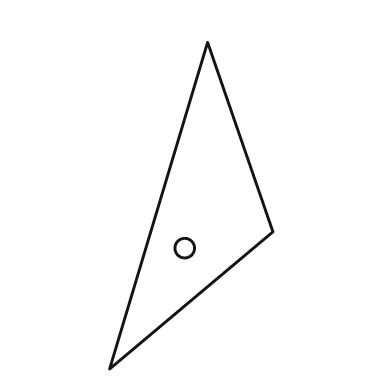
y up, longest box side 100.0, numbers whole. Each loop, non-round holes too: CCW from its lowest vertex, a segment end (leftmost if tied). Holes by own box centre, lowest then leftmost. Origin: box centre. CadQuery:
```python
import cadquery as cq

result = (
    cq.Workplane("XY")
    .moveTo(-25.0, -50.0)
    .lineTo(25.0, -8.0)
    .lineTo(5.0, 50.0)
    .close()
    .moveTo(-2.0, -13.0)
    .circle(3.0)
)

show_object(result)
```